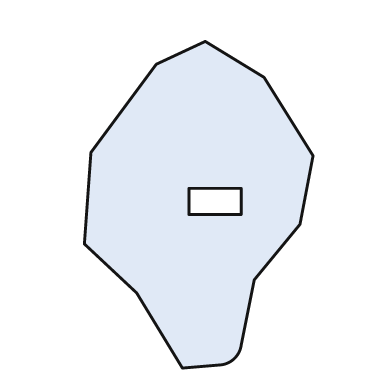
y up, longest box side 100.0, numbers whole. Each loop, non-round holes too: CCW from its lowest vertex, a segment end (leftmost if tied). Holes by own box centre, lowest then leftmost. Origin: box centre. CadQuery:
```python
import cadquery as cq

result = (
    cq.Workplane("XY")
    .moveTo(-5.0, -50.0)
    .lineTo(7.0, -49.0)
    .threePointArc((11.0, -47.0), (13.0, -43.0))
    .lineTo(17.0, -23.0)
    .lineTo(31.0, -6.0)
    .lineTo(35.0, 15.0)
    .lineTo(20.0, 39.0)
    .lineTo(2.0, 50.0)
    .lineTo(-13.0, 43.0)
    .lineTo(-33.0, 16.0)
    .lineTo(-35.0, -12.0)
    .lineTo(-19.0, -27.0)
    .close()
    .moveTo(-3.0, -3.0)
    .lineTo(13.0, -3.0)
    .lineTo(13.0, 5.0)
    .lineTo(-3.0, 5.0)
    .close()
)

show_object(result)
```